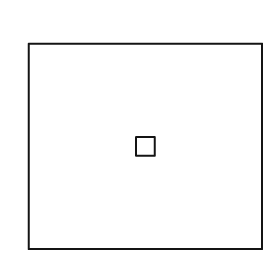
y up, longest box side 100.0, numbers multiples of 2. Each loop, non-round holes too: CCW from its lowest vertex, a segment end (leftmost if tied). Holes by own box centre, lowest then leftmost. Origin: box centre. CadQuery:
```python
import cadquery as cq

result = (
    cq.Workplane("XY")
    .moveTo(-50.0, -44.0)
    .lineTo(50.0, -44.0)
    .lineTo(50.0, 44.0)
    .lineTo(-50.0, 44.0)
    .close()
    .moveTo(-4.0, -4.0)
    .lineTo(4.0, -4.0)
    .lineTo(4.0, 4.0)
    .lineTo(-4.0, 4.0)
    .close()
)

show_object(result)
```